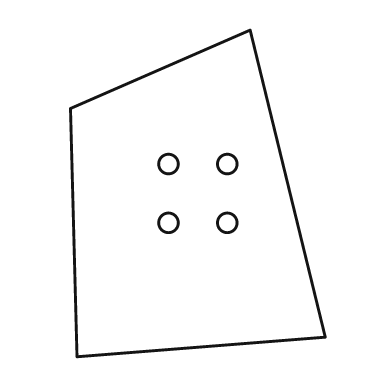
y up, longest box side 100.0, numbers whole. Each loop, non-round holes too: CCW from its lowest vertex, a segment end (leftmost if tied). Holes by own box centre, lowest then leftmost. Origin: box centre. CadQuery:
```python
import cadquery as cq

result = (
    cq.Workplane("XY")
    .moveTo(-37.0, -50.0)
    .lineTo(39.0, -44.0)
    .lineTo(16.0, 50.0)
    .lineTo(-39.0, 26.0)
    .close()
    .moveTo(-9.0, -9.0)
    .circle(3.0)
    .moveTo(9.0, -9.0)
    .circle(3.0)
    .moveTo(-9.0, 9.0)
    .circle(3.0)
    .moveTo(9.0, 9.0)
    .circle(3.0)
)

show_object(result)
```